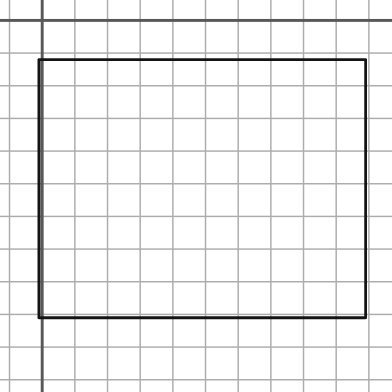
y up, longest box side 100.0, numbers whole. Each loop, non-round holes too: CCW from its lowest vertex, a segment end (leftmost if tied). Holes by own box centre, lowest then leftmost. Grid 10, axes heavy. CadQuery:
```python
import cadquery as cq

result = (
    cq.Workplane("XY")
    .moveTo(-1.0, -91.0)
    .lineTo(99.0, -91.0)
    .lineTo(99.0, -12.0)
    .lineTo(-1.0, -12.0)
    .close()
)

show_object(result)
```